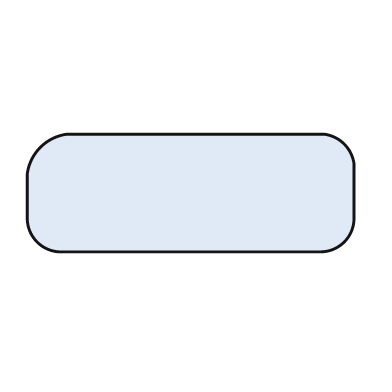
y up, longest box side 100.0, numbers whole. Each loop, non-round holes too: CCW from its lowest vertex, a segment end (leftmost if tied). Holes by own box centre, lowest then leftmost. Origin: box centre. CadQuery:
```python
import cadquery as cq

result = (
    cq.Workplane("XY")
    .moveTo(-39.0, -18.0)
    .lineTo(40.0, -18.0)
    .threePointArc((47.0, -15.0), (50.0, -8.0))
    .lineTo(50.0, 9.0)
    .threePointArc((47.0, 15.0), (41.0, 18.0))
    .lineTo(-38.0, 18.0)
    .threePointArc((-46.0, 14.0), (-50.0, 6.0))
    .lineTo(-50.0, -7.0)
    .threePointArc((-47.0, -15.0), (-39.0, -18.0))
    .close()
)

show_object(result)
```